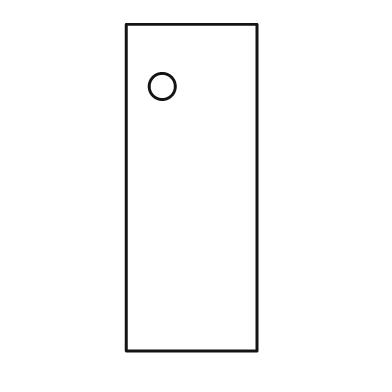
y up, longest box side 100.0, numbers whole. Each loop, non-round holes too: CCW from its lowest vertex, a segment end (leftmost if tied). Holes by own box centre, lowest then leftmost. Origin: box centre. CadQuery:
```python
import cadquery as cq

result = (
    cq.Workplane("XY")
    .moveTo(-20.0, -50.0)
    .lineTo(20.0, -50.0)
    .lineTo(20.0, 50.0)
    .lineTo(-20.0, 50.0)
    .close()
    .moveTo(-9.0, 31.0)
    .circle(4.0)
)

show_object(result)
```